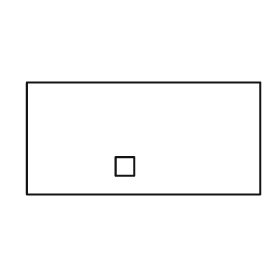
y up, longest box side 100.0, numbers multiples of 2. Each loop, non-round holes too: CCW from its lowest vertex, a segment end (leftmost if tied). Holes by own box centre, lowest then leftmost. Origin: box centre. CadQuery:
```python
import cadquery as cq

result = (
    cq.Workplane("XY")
    .moveTo(-50.0, -24.0)
    .lineTo(50.0, -24.0)
    .lineTo(50.0, 24.0)
    .lineTo(-50.0, 24.0)
    .close()
    .moveTo(-12.0, -16.0)
    .lineTo(-4.0, -16.0)
    .lineTo(-4.0, -8.0)
    .lineTo(-12.0, -8.0)
    .close()
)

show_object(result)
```